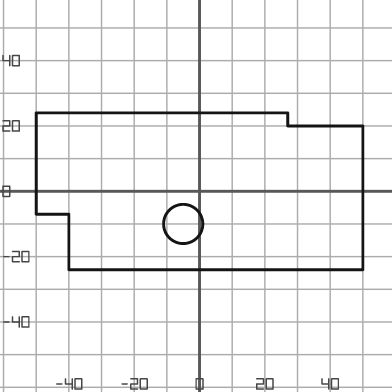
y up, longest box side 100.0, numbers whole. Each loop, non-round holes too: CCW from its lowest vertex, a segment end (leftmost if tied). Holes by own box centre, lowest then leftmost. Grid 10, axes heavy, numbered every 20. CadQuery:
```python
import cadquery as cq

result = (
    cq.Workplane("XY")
    .moveTo(-40.0, -24.0)
    .lineTo(50.0, -24.0)
    .lineTo(50.0, 20.0)
    .lineTo(27.0, 20.0)
    .lineTo(27.0, 24.0)
    .lineTo(-50.0, 24.0)
    .lineTo(-50.0, -7.0)
    .lineTo(-40.0, -7.0)
    .close()
    .moveTo(-5.0, -10.0)
    .circle(6.0)
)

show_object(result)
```